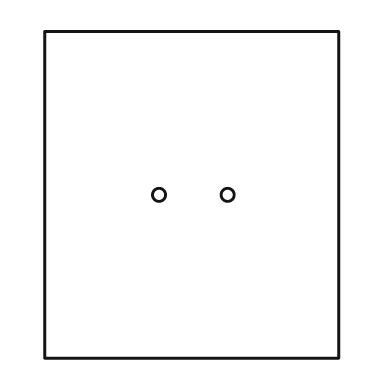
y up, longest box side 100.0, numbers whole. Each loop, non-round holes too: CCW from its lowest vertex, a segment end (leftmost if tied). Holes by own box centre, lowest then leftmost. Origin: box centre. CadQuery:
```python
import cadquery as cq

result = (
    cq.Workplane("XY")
    .moveTo(-45.0, -50.0)
    .lineTo(45.0, -50.0)
    .lineTo(45.0, 50.0)
    .lineTo(-45.0, 50.0)
    .close()
    .moveTo(-10.0, 0.0)
    .circle(2.0)
    .moveTo(11.0, 0.0)
    .circle(2.0)
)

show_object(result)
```